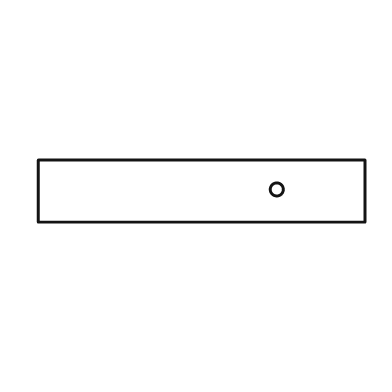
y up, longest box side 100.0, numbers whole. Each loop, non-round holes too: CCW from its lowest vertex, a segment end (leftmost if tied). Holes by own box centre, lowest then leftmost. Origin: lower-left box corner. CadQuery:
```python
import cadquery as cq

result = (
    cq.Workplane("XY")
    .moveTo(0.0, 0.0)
    .lineTo(100.0, 0.0)
    .lineTo(100.0, 19.0)
    .lineTo(0.0, 19.0)
    .close()
    .moveTo(73.0, 10.0)
    .circle(2.0)
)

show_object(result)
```